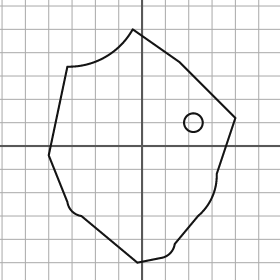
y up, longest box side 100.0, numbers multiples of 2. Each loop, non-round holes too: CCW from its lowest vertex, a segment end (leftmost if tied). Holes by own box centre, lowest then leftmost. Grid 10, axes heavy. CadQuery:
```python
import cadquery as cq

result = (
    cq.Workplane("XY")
    .moveTo(-2.0, -50.0)
    .lineTo(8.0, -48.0)
    .threePointArc((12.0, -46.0), (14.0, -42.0))
    .lineTo(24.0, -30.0)
    .threePointArc((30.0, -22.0), (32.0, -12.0))
    .lineTo(40.0, 12.0)
    .lineTo(16.0, 36.0)
    .lineTo(-4.0, 50.0)
    .threePointArc((-16.0, 38.0), (-32.0, 34.0))
    .lineTo(-40.0, -4.0)
    .lineTo(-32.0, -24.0)
    .threePointArc((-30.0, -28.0), (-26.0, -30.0))
    .close()
    .moveTo(22.0, 10.0)
    .circle(4.0)
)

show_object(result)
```